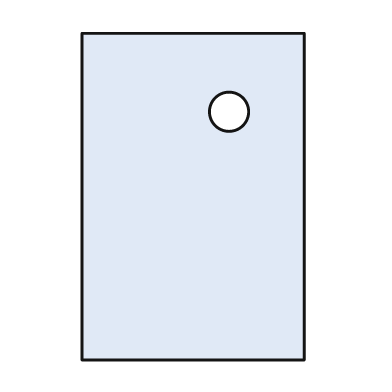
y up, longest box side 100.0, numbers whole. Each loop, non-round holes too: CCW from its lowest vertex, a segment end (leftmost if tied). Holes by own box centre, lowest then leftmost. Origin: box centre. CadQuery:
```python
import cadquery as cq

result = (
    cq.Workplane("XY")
    .moveTo(-34.0, -50.0)
    .lineTo(34.0, -50.0)
    .lineTo(34.0, 50.0)
    .lineTo(-34.0, 50.0)
    .close()
    .moveTo(11.0, 26.0)
    .circle(6.0)
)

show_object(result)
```